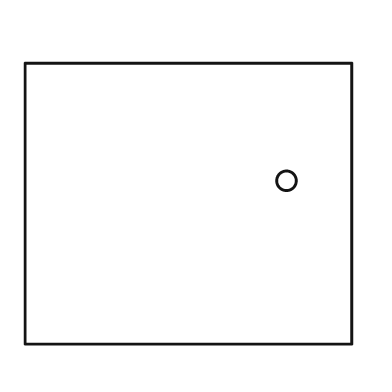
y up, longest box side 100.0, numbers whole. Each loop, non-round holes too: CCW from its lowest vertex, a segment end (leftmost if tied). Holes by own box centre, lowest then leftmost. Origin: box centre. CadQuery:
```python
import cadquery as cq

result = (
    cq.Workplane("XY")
    .moveTo(-50.0, -43.0)
    .lineTo(50.0, -43.0)
    .lineTo(50.0, 43.0)
    .lineTo(-50.0, 43.0)
    .close()
    .moveTo(30.0, 7.0)
    .circle(3.0)
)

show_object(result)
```